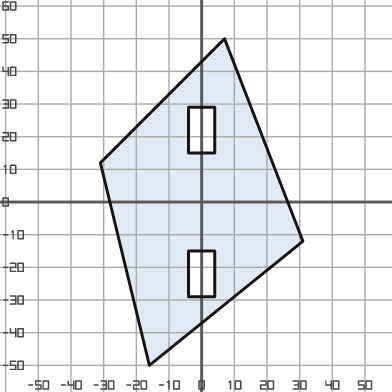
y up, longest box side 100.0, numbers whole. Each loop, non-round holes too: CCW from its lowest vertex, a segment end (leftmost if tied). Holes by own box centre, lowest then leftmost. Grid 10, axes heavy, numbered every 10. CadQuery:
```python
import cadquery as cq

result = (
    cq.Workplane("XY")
    .moveTo(-16.0, -50.0)
    .lineTo(31.0, -12.0)
    .lineTo(7.0, 50.0)
    .lineTo(-31.0, 12.0)
    .close()
    .moveTo(-4.0, -29.0)
    .lineTo(4.0, -29.0)
    .lineTo(4.0, -15.0)
    .lineTo(-4.0, -15.0)
    .close()
    .moveTo(-4.0, 15.0)
    .lineTo(4.0, 15.0)
    .lineTo(4.0, 29.0)
    .lineTo(-4.0, 29.0)
    .close()
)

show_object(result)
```